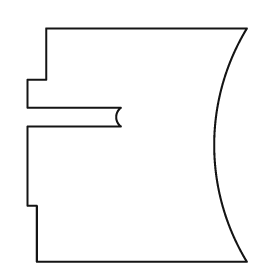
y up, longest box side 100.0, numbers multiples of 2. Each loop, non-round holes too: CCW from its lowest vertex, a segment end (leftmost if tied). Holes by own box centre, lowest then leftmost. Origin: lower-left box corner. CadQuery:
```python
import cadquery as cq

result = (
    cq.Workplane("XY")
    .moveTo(4.0, 0.0)
    .lineTo(94.0, 0.0)
    .threePointArc((80.0, 50.0), (94.0, 100.0))
    .lineTo(8.0, 100.0)
    .lineTo(8.0, 78.0)
    .lineTo(0.0, 78.0)
    .lineTo(0.0, 66.0)
    .lineTo(40.0, 66.0)
    .threePointArc((38.0, 62.0), (40.0, 58.0))
    .lineTo(0.0, 58.0)
    .lineTo(0.0, 24.0)
    .lineTo(4.0, 24.0)
    .close()
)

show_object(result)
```